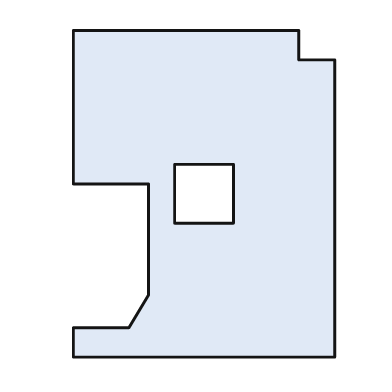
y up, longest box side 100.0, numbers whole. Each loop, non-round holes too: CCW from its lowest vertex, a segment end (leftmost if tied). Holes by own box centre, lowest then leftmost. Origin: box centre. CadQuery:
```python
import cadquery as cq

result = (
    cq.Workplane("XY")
    .moveTo(-40.0, -50.0)
    .lineTo(40.0, -50.0)
    .lineTo(40.0, 41.0)
    .lineTo(29.0, 41.0)
    .lineTo(29.0, 50.0)
    .lineTo(-40.0, 50.0)
    .lineTo(-40.0, 3.0)
    .lineTo(-17.0, 3.0)
    .lineTo(-17.0, -31.0)
    .lineTo(-23.0, -41.0)
    .lineTo(-40.0, -41.0)
    .close()
    .moveTo(-9.0, -9.0)
    .lineTo(9.0, -9.0)
    .lineTo(9.0, 9.0)
    .lineTo(-9.0, 9.0)
    .close()
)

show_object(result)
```